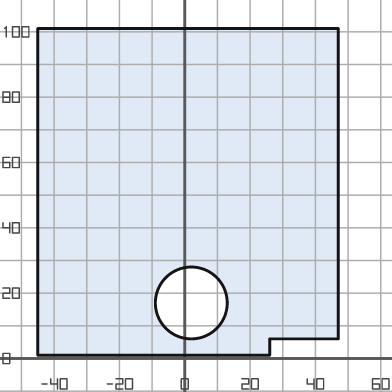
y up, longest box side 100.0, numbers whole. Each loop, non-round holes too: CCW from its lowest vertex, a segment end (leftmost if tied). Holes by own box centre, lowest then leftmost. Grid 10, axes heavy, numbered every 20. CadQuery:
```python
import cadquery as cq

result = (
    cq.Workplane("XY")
    .moveTo(-45.0, 1.0)
    .lineTo(26.0, 1.0)
    .lineTo(26.0, 6.0)
    .lineTo(47.0, 6.0)
    .lineTo(47.0, 101.0)
    .lineTo(-45.0, 101.0)
    .close()
    .moveTo(2.0, 17.0)
    .circle(11.0)
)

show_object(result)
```